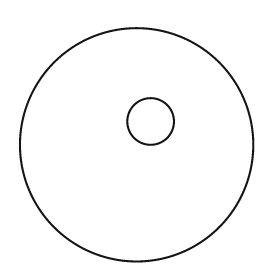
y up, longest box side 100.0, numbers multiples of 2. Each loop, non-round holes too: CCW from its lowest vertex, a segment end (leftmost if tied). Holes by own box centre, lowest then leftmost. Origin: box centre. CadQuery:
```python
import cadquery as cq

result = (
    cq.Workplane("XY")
    .moveTo(0.0, 0.0)
    .circle(50.0)
    .moveTo(6.0, 10.0)
    .circle(10.0)
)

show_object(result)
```